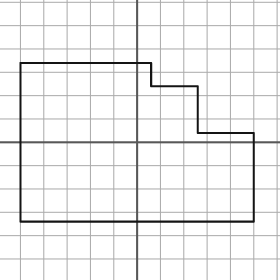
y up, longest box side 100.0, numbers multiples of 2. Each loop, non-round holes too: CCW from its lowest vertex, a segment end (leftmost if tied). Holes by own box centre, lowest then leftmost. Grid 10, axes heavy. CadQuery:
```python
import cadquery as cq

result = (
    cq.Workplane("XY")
    .moveTo(-50.0, -34.0)
    .lineTo(50.0, -34.0)
    .lineTo(50.0, 4.0)
    .lineTo(26.0, 4.0)
    .lineTo(26.0, 24.0)
    .lineTo(6.0, 24.0)
    .lineTo(6.0, 34.0)
    .lineTo(-50.0, 34.0)
    .close()
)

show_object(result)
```